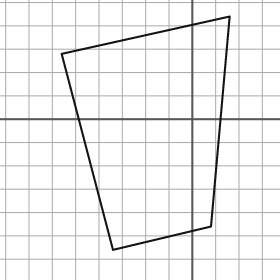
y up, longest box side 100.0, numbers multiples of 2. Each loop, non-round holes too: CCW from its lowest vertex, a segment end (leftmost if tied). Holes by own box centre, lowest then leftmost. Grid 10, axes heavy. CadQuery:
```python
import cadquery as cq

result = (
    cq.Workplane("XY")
    .moveTo(-34.0, -56.0)
    .lineTo(8.0, -46.0)
    .lineTo(16.0, 44.0)
    .lineTo(-56.0, 28.0)
    .close()
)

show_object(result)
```